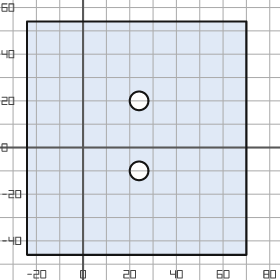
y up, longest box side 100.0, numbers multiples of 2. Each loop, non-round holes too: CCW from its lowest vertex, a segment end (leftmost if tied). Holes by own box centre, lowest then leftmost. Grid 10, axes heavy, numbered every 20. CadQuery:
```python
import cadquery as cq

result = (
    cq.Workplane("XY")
    .moveTo(-24.0, -46.0)
    .lineTo(70.0, -46.0)
    .lineTo(70.0, 54.0)
    .lineTo(-24.0, 54.0)
    .close()
    .moveTo(24.0, -10.0)
    .circle(4.0)
    .moveTo(24.0, 20.0)
    .circle(4.0)
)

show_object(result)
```